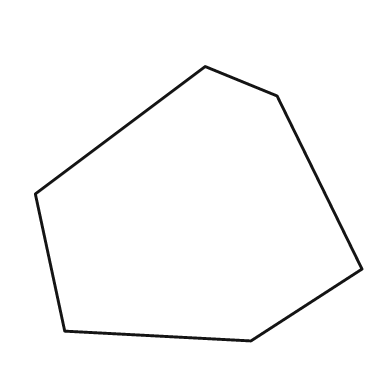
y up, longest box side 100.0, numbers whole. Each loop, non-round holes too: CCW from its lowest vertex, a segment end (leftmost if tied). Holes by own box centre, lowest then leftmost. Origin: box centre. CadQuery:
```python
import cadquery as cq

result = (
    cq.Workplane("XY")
    .moveTo(16.0, -42.0)
    .lineTo(50.0, -20.0)
    .lineTo(24.0, 33.0)
    .lineTo(2.0, 42.0)
    .lineTo(-50.0, 3.0)
    .lineTo(-41.0, -39.0)
    .close()
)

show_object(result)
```